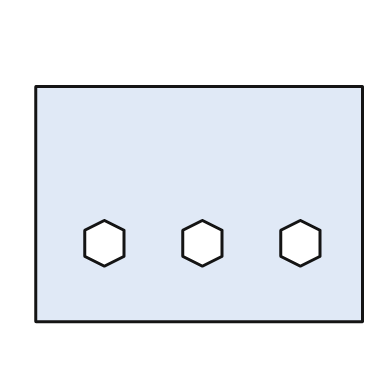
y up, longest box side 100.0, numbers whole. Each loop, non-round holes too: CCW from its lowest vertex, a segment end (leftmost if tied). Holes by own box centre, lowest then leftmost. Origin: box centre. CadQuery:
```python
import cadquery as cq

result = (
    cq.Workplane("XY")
    .moveTo(-50.0, -36.0)
    .lineTo(50.0, -36.0)
    .lineTo(50.0, 36.0)
    .lineTo(-50.0, 36.0)
    .close()
    .moveTo(-29.0, -19.0)
    .lineTo(-23.0, -16.0)
    .lineTo(-23.0, -8.0)
    .lineTo(-29.0, -5.0)
    .lineTo(-35.0, -8.0)
    .lineTo(-35.0, -16.0)
    .close()
    .moveTo(1.0, -19.0)
    .lineTo(7.0, -16.0)
    .lineTo(7.0, -8.0)
    .lineTo(1.0, -5.0)
    .lineTo(-5.0, -8.0)
    .lineTo(-5.0, -16.0)
    .close()
    .moveTo(31.0, -19.0)
    .lineTo(37.0, -16.0)
    .lineTo(37.0, -8.0)
    .lineTo(31.0, -5.0)
    .lineTo(25.0, -8.0)
    .lineTo(25.0, -16.0)
    .close()
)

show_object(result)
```